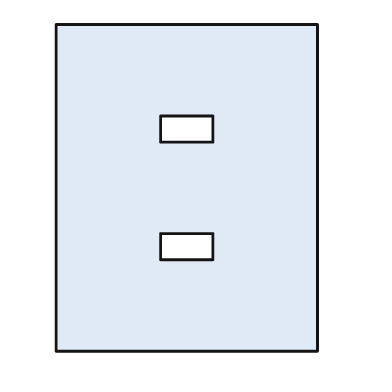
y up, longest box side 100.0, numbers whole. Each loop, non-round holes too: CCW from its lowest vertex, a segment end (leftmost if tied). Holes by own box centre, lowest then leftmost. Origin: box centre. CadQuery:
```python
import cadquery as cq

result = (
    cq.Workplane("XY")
    .moveTo(-40.0, -50.0)
    .lineTo(40.0, -50.0)
    .lineTo(40.0, 50.0)
    .lineTo(-40.0, 50.0)
    .close()
    .moveTo(-8.0, -22.0)
    .lineTo(8.0, -22.0)
    .lineTo(8.0, -14.0)
    .lineTo(-8.0, -14.0)
    .close()
    .moveTo(-8.0, 14.0)
    .lineTo(8.0, 14.0)
    .lineTo(8.0, 22.0)
    .lineTo(-8.0, 22.0)
    .close()
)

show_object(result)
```